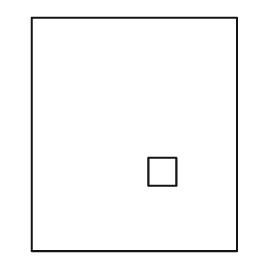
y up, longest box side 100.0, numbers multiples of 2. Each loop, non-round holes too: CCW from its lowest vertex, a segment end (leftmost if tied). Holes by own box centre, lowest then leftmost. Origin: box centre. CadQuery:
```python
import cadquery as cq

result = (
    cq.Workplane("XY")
    .moveTo(-44.0, -50.0)
    .lineTo(44.0, -50.0)
    .lineTo(44.0, 50.0)
    .lineTo(-44.0, 50.0)
    .close()
    .moveTo(6.0, -22.0)
    .lineTo(18.0, -22.0)
    .lineTo(18.0, -10.0)
    .lineTo(6.0, -10.0)
    .close()
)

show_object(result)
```